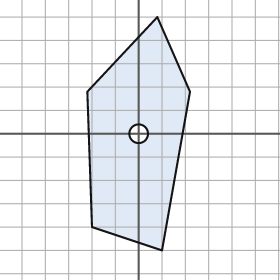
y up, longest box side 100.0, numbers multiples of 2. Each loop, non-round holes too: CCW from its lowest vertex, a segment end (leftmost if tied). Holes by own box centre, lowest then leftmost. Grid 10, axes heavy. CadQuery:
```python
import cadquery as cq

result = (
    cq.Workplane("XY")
    .moveTo(10.0, -50.0)
    .lineTo(22.0, 18.0)
    .lineTo(8.0, 50.0)
    .lineTo(-22.0, 18.0)
    .lineTo(-20.0, -40.0)
    .close()
    .moveTo(0.0, 0.0)
    .circle(4.0)
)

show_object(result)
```